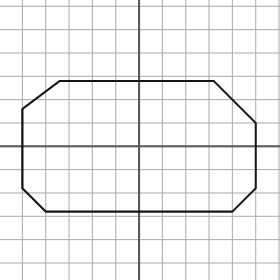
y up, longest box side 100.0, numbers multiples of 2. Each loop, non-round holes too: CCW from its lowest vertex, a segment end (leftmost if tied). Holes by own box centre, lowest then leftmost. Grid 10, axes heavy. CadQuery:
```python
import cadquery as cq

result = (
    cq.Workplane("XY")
    .moveTo(-40.0, -28.0)
    .lineTo(40.0, -28.0)
    .lineTo(50.0, -18.0)
    .lineTo(50.0, 10.0)
    .lineTo(32.0, 28.0)
    .lineTo(-34.0, 28.0)
    .lineTo(-50.0, 16.0)
    .lineTo(-50.0, -18.0)
    .close()
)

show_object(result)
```